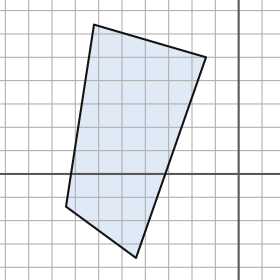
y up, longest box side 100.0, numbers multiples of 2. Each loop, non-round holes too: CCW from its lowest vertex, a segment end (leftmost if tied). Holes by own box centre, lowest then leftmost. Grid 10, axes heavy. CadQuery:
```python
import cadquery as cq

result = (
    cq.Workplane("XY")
    .moveTo(-44.0, -36.0)
    .lineTo(-14.0, 50.0)
    .lineTo(-62.0, 64.0)
    .lineTo(-74.0, -14.0)
    .close()
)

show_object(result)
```